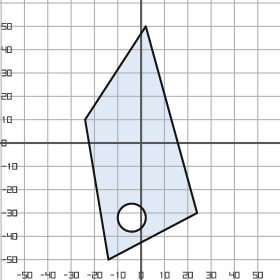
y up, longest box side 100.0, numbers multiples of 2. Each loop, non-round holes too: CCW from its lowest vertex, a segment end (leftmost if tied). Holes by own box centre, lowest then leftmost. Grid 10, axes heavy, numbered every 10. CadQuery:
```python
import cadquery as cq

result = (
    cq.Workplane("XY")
    .moveTo(-14.0, -50.0)
    .lineTo(24.0, -30.0)
    .lineTo(2.0, 50.0)
    .lineTo(-24.0, 10.0)
    .close()
    .moveTo(-4.0, -32.0)
    .circle(6.0)
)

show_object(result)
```